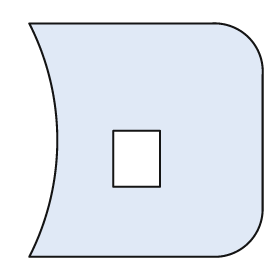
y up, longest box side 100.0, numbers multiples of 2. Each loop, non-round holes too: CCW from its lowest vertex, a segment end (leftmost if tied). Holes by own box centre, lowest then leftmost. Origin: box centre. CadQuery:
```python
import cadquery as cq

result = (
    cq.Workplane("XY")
    .moveTo(-50.0, -50.0)
    .lineTo(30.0, -50.0)
    .threePointArc((44.0, -44.0), (50.0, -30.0))
    .lineTo(50.0, 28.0)
    .threePointArc((44.0, 44.0), (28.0, 50.0))
    .lineTo(-50.0, 50.0)
    .threePointArc((-38.0, 0.0), (-50.0, -50.0))
    .close()
    .moveTo(-14.0, -20.0)
    .lineTo(6.0, -20.0)
    .lineTo(6.0, 4.0)
    .lineTo(-14.0, 4.0)
    .close()
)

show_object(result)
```